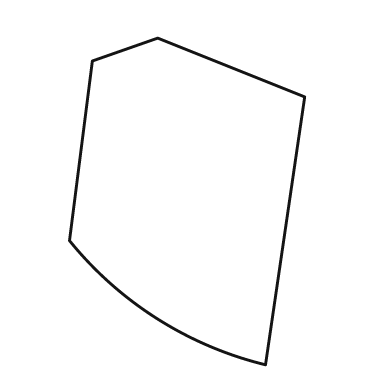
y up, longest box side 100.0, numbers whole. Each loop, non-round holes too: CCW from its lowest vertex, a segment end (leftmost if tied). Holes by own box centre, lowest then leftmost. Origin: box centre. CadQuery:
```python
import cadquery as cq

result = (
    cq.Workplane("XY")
    .moveTo(24.0, -50.0)
    .lineTo(36.0, 32.0)
    .lineTo(-9.0, 50.0)
    .lineTo(-29.0, 43.0)
    .lineTo(-36.0, -12.0)
    .threePointArc((-9.0, -36.0), (24.0, -50.0))
    .close()
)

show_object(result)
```